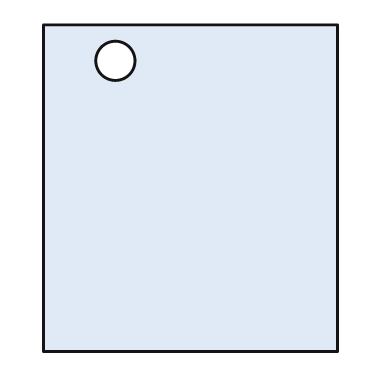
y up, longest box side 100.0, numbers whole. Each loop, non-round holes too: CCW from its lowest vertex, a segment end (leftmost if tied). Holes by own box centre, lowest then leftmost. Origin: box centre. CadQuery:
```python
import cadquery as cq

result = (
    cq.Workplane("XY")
    .moveTo(-45.0, -50.0)
    .lineTo(45.0, -50.0)
    .lineTo(45.0, 50.0)
    .lineTo(-45.0, 50.0)
    .close()
    .moveTo(-23.0, 39.0)
    .circle(6.0)
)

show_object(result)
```